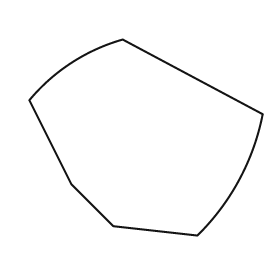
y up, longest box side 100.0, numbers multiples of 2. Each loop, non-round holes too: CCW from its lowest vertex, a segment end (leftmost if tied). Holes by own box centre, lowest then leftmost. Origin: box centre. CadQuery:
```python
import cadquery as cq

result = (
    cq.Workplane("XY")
    .moveTo(22.0, -42.0)
    .threePointArc((40.0, -18.0), (50.0, 10.0))
    .lineTo(-10.0, 42.0)
    .threePointArc((-32.0, 32.0), (-50.0, 16.0))
    .lineTo(-32.0, -20.0)
    .lineTo(-14.0, -38.0)
    .close()
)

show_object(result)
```